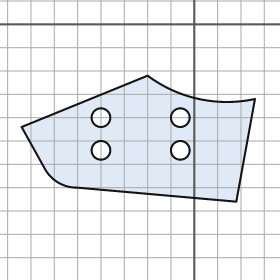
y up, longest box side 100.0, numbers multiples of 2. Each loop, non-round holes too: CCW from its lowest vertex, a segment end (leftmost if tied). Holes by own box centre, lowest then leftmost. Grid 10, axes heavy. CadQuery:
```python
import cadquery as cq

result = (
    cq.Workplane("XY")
    .moveTo(18.0, -76.0)
    .lineTo(26.0, -32.0)
    .threePointArc((2.0, -32.0), (-20.0, -22.0))
    .lineTo(-74.0, -44.0)
    .lineTo(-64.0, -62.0)
    .threePointArc((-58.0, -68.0), (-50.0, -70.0))
    .close()
    .moveTo(-40.0, -54.0)
    .circle(4.0)
    .moveTo(-6.0, -54.0)
    .circle(4.0)
    .moveTo(-40.0, -40.0)
    .circle(4.0)
    .moveTo(-6.0, -40.0)
    .circle(4.0)
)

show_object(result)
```